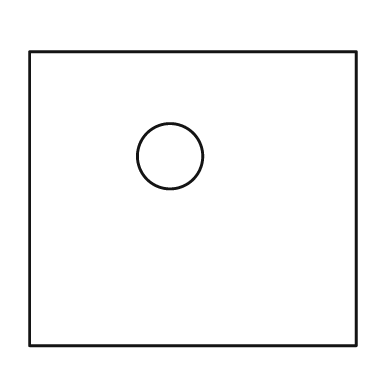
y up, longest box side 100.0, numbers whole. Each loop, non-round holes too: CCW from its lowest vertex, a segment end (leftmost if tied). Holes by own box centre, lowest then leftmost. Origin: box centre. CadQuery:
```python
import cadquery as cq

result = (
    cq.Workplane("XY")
    .moveTo(-50.0, -45.0)
    .lineTo(50.0, -45.0)
    .lineTo(50.0, 45.0)
    .lineTo(-50.0, 45.0)
    .close()
    .moveTo(-7.0, 13.0)
    .circle(10.0)
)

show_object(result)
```